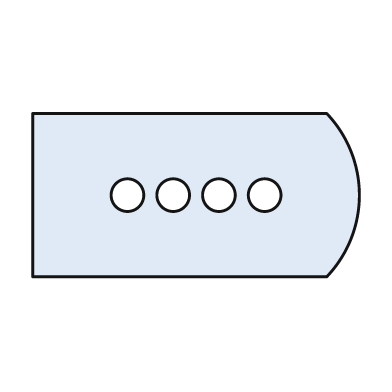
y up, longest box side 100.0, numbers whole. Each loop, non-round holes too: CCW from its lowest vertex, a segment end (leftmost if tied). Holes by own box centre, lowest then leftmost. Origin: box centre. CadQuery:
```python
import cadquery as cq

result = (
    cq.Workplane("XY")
    .moveTo(-50.0, -25.0)
    .lineTo(40.0, -25.0)
    .threePointArc((50.0, 0.0), (40.0, 25.0))
    .lineTo(-50.0, 25.0)
    .close()
    .moveTo(-21.0, 0.0)
    .circle(5.0)
    .moveTo(-7.0, 0.0)
    .circle(5.0)
    .moveTo(7.0, 0.0)
    .circle(5.0)
    .moveTo(21.0, 0.0)
    .circle(5.0)
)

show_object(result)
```